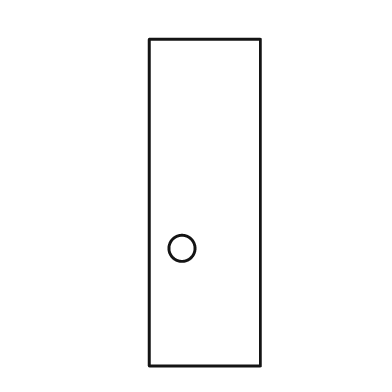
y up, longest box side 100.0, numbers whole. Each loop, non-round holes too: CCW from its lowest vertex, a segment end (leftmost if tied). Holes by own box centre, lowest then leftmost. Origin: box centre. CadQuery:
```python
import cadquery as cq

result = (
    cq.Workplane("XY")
    .moveTo(-17.0, -50.0)
    .lineTo(17.0, -50.0)
    .lineTo(17.0, 50.0)
    .lineTo(-17.0, 50.0)
    .close()
    .moveTo(-7.0, -14.0)
    .circle(4.0)
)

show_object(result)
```